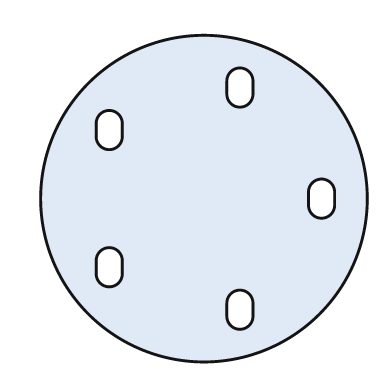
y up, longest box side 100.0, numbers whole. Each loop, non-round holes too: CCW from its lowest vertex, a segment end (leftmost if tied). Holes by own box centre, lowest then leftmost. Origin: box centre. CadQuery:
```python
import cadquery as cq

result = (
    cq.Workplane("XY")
    .moveTo(0.0, 0.0)
    .circle(50.0)
    .moveTo(7.0, -36.0)
    .threePointArc((11.0, -40.0), (15.0, -36.0))
    .lineTo(15.0, -32.0)
    .threePointArc((11.0, -28.0), (7.0, -32.0))
    .close()
    .moveTo(-33.0, -23.0)
    .threePointArc((-29.0, -27.0), (-25.0, -23.0))
    .lineTo(-25.0, -19.0)
    .threePointArc((-29.0, -15.0), (-33.0, -19.0))
    .close()
    .moveTo(32.0, -2.0)
    .threePointArc((36.0, -6.0), (40.0, -2.0))
    .lineTo(40.0, 2.0)
    .threePointArc((36.0, 6.0), (32.0, 2.0))
    .close()
    .moveTo(-33.0, 19.0)
    .threePointArc((-29.0, 15.0), (-25.0, 19.0))
    .lineTo(-25.0, 23.0)
    .threePointArc((-29.0, 27.0), (-33.0, 23.0))
    .close()
    .moveTo(7.0, 32.0)
    .threePointArc((11.0, 28.0), (15.0, 32.0))
    .lineTo(15.0, 36.0)
    .threePointArc((11.0, 40.0), (7.0, 36.0))
    .close()
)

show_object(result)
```